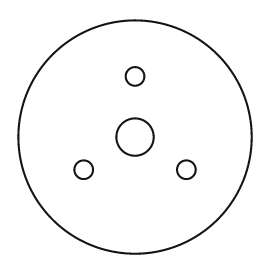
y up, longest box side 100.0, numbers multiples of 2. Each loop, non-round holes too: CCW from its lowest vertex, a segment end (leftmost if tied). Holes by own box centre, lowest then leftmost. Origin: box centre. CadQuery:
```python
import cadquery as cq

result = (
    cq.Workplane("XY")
    .moveTo(0.0, 0.0)
    .circle(50.0)
    .moveTo(-22.0, -14.0)
    .circle(4.0)
    .moveTo(22.0, -14.0)
    .circle(4.0)
    .moveTo(0.0, 0.0)
    .circle(8.0)
    .moveTo(0.0, 26.0)
    .circle(4.0)
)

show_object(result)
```